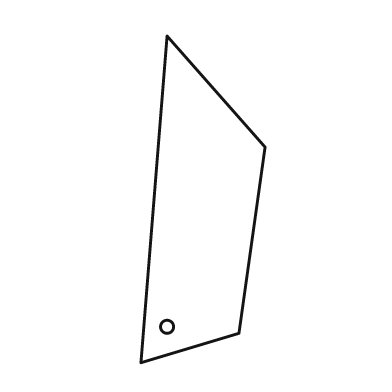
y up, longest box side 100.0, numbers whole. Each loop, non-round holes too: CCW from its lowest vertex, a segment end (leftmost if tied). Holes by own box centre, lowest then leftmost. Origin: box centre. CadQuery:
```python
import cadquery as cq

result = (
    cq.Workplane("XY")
    .moveTo(-19.0, -50.0)
    .lineTo(11.0, -41.0)
    .lineTo(19.0, 16.0)
    .lineTo(-11.0, 50.0)
    .close()
    .moveTo(-11.0, -39.0)
    .circle(2.0)
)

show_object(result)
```